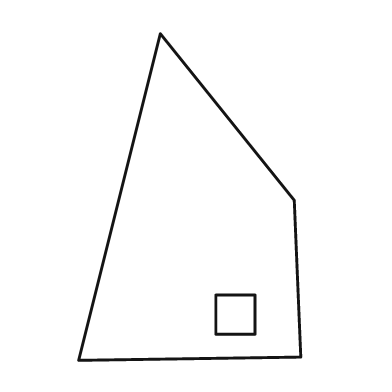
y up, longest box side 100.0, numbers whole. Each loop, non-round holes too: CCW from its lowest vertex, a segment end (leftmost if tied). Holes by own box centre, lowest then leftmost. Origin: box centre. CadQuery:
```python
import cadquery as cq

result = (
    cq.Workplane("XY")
    .moveTo(-34.0, -50.0)
    .lineTo(34.0, -49.0)
    .lineTo(32.0, -1.0)
    .lineTo(-9.0, 50.0)
    .close()
    .moveTo(8.0, -42.0)
    .lineTo(20.0, -42.0)
    .lineTo(20.0, -30.0)
    .lineTo(8.0, -30.0)
    .close()
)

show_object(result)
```